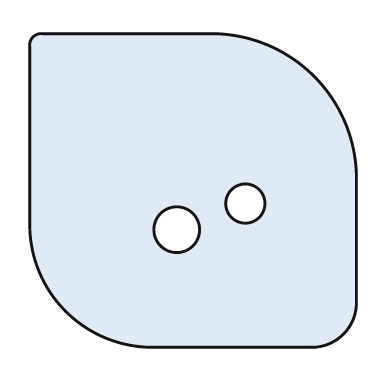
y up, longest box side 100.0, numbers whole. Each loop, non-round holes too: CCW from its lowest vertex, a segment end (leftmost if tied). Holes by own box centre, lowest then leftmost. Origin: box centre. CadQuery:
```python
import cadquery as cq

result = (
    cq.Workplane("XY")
    .moveTo(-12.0, -48.0)
    .lineTo(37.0, -48.0)
    .threePointArc((46.0, -44.0), (50.0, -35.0))
    .lineTo(50.0, 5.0)
    .threePointArc((37.0, 35.0), (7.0, 48.0))
    .lineTo(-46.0, 48.0)
    .threePointArc((-49.0, 47.0), (-50.0, 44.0))
    .lineTo(-50.0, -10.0)
    .threePointArc((-39.0, -37.0), (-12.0, -48.0))
    .close()
    .moveTo(-5.0, -12.0)
    .circle(7.0)
    .moveTo(16.0, -4.0)
    .circle(6.0)
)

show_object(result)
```